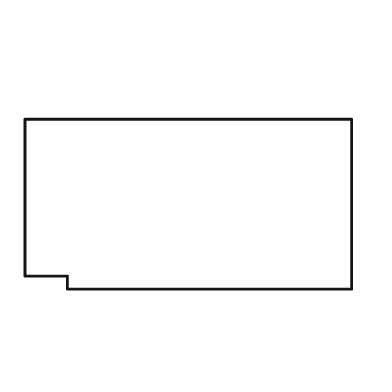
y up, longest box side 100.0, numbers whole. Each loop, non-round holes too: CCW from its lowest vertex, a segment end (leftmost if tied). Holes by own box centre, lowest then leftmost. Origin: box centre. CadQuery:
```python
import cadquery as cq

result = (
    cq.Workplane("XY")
    .moveTo(-37.0, -26.0)
    .lineTo(50.0, -26.0)
    .lineTo(50.0, 26.0)
    .lineTo(-50.0, 26.0)
    .lineTo(-50.0, -22.0)
    .lineTo(-37.0, -22.0)
    .close()
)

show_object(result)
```